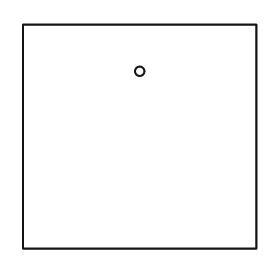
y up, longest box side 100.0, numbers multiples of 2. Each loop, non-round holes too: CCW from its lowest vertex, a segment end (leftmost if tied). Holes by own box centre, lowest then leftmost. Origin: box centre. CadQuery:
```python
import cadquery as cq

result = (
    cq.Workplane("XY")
    .moveTo(-50.0, -48.0)
    .lineTo(50.0, -48.0)
    .lineTo(50.0, 48.0)
    .lineTo(-50.0, 48.0)
    .close()
    .moveTo(0.0, 28.0)
    .circle(2.0)
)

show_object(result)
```